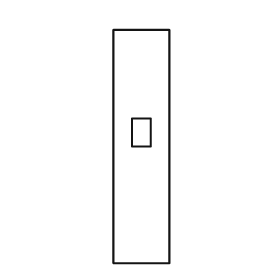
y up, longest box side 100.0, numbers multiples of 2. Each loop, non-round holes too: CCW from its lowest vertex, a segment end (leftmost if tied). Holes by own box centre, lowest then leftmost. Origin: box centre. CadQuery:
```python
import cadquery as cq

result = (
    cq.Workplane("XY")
    .moveTo(-12.0, -50.0)
    .lineTo(12.0, -50.0)
    .lineTo(12.0, 50.0)
    .lineTo(-12.0, 50.0)
    .close()
    .moveTo(-4.0, 0.0)
    .lineTo(4.0, 0.0)
    .lineTo(4.0, 12.0)
    .lineTo(-4.0, 12.0)
    .close()
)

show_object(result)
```